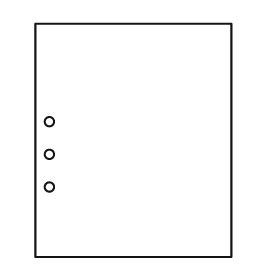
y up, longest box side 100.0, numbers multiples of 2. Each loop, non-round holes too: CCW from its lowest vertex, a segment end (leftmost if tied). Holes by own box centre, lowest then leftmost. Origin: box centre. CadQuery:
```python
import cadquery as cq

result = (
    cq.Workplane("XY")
    .moveTo(-42.0, -50.0)
    .lineTo(42.0, -50.0)
    .lineTo(42.0, 50.0)
    .lineTo(-42.0, 50.0)
    .close()
    .moveTo(-36.0, -20.0)
    .circle(2.0)
    .moveTo(-36.0, -6.0)
    .circle(2.0)
    .moveTo(-36.0, 8.0)
    .circle(2.0)
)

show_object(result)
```